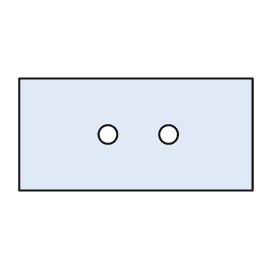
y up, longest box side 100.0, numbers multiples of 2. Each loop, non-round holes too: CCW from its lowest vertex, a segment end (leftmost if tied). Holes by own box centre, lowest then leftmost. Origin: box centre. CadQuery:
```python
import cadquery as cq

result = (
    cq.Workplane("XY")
    .moveTo(-50.0, -24.0)
    .lineTo(50.0, -24.0)
    .lineTo(50.0, 24.0)
    .lineTo(-50.0, 24.0)
    .close()
    .moveTo(-12.0, 0.0)
    .circle(4.0)
    .moveTo(14.0, 0.0)
    .circle(4.0)
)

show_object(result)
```